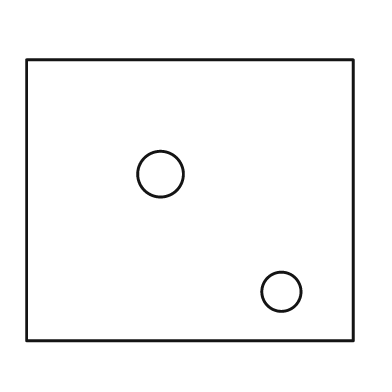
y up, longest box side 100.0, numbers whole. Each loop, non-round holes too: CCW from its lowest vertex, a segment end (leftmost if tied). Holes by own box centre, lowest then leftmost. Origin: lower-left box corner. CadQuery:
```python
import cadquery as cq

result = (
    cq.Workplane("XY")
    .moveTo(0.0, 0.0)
    .lineTo(100.0, 0.0)
    .lineTo(100.0, 86.0)
    .lineTo(0.0, 86.0)
    .close()
    .moveTo(78.0, 15.0)
    .circle(6.0)
    .moveTo(41.0, 51.0)
    .circle(7.0)
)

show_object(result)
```